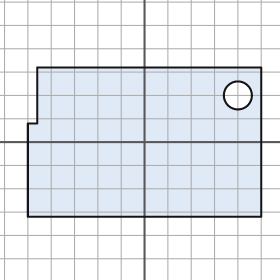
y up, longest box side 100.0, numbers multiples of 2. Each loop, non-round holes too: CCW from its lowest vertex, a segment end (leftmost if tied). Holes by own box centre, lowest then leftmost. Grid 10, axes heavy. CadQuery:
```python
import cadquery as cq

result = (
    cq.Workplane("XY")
    .moveTo(-50.0, -32.0)
    .lineTo(50.0, -32.0)
    .lineTo(50.0, 32.0)
    .lineTo(-46.0, 32.0)
    .lineTo(-46.0, 8.0)
    .lineTo(-50.0, 8.0)
    .close()
    .moveTo(40.0, 20.0)
    .circle(6.0)
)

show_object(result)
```